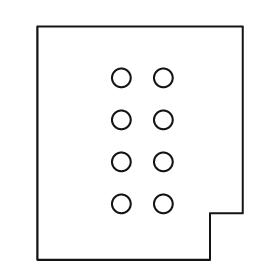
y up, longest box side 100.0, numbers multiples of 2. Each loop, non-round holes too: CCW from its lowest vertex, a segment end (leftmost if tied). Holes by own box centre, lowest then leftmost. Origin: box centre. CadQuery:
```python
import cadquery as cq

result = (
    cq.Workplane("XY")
    .moveTo(-44.0, -50.0)
    .lineTo(30.0, -50.0)
    .lineTo(30.0, -30.0)
    .lineTo(44.0, -30.0)
    .lineTo(44.0, 50.0)
    .lineTo(-44.0, 50.0)
    .close()
    .moveTo(-8.0, -26.0)
    .circle(4.0)
    .moveTo(10.0, -26.0)
    .circle(4.0)
    .moveTo(-8.0, -8.0)
    .circle(4.0)
    .moveTo(10.0, -8.0)
    .circle(4.0)
    .moveTo(-8.0, 10.0)
    .circle(4.0)
    .moveTo(10.0, 10.0)
    .circle(4.0)
    .moveTo(-8.0, 28.0)
    .circle(4.0)
    .moveTo(10.0, 28.0)
    .circle(4.0)
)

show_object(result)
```